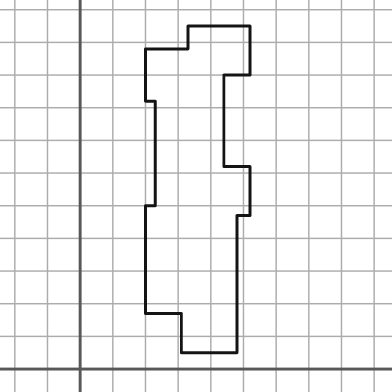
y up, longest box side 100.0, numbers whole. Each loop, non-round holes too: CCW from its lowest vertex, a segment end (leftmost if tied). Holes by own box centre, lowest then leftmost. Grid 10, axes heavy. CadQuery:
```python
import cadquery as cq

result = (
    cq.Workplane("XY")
    .moveTo(31.0, 5.0)
    .lineTo(48.0, 5.0)
    .lineTo(48.0, 47.0)
    .lineTo(52.0, 47.0)
    .lineTo(52.0, 62.0)
    .lineTo(44.0, 62.0)
    .lineTo(44.0, 90.0)
    .lineTo(52.0, 90.0)
    .lineTo(52.0, 105.0)
    .lineTo(33.0, 105.0)
    .lineTo(33.0, 98.0)
    .lineTo(20.0, 98.0)
    .lineTo(20.0, 82.0)
    .lineTo(23.0, 82.0)
    .lineTo(23.0, 50.0)
    .lineTo(20.0, 50.0)
    .lineTo(20.0, 17.0)
    .lineTo(31.0, 17.0)
    .close()
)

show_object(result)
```